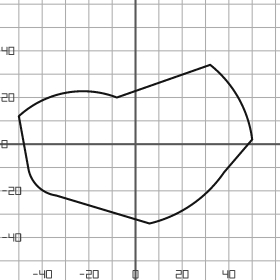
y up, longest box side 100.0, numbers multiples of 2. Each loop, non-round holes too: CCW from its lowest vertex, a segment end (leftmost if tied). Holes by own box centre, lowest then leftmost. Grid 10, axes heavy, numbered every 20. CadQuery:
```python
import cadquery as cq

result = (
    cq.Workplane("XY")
    .moveTo(6.0, -34.0)
    .threePointArc((24.0, -26.0), (38.0, -12.0))
    .lineTo(50.0, 2.0)
    .threePointArc((44.0, 20.0), (32.0, 34.0))
    .lineTo(-8.0, 20.0)
    .threePointArc((-30.0, 22.0), (-50.0, 12.0))
    .lineTo(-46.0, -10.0)
    .threePointArc((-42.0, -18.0), (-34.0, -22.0))
    .close()
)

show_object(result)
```